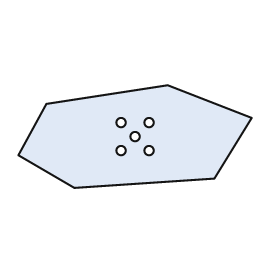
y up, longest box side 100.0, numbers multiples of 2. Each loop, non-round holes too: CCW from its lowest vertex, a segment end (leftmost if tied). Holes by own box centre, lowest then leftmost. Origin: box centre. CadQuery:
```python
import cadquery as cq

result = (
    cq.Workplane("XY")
    .moveTo(-26.0, -22.0)
    .lineTo(34.0, -18.0)
    .lineTo(50.0, 8.0)
    .lineTo(14.0, 22.0)
    .lineTo(-38.0, 14.0)
    .lineTo(-50.0, -8.0)
    .close()
    .moveTo(-6.0, -6.0)
    .circle(2.0)
    .moveTo(6.0, -6.0)
    .circle(2.0)
    .moveTo(0.0, 0.0)
    .circle(2.0)
    .moveTo(-6.0, 6.0)
    .circle(2.0)
    .moveTo(6.0, 6.0)
    .circle(2.0)
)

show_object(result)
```